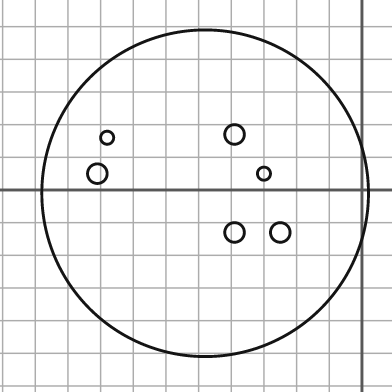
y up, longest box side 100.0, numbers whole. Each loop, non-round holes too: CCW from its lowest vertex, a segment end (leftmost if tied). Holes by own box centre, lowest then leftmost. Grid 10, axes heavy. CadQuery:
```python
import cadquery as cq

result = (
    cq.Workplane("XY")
    .moveTo(-48.0, -1.0)
    .circle(50.0)
    .moveTo(-39.0, -13.0)
    .circle(3.0)
    .moveTo(-25.0, -13.0)
    .circle(3.0)
    .moveTo(-81.0, 5.0)
    .circle(3.0)
    .moveTo(-30.0, 5.0)
    .circle(2.0)
    .moveTo(-78.0, 16.0)
    .circle(2.0)
    .moveTo(-39.0, 17.0)
    .circle(3.0)
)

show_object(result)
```